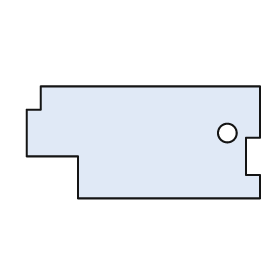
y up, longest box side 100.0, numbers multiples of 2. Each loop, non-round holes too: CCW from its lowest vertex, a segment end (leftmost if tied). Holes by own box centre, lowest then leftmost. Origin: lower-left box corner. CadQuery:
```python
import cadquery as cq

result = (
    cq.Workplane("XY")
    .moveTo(22.0, 0.0)
    .lineTo(100.0, 0.0)
    .lineTo(100.0, 10.0)
    .lineTo(94.0, 10.0)
    .lineTo(94.0, 26.0)
    .lineTo(100.0, 26.0)
    .lineTo(100.0, 48.0)
    .lineTo(6.0, 48.0)
    .lineTo(6.0, 38.0)
    .lineTo(0.0, 38.0)
    .lineTo(0.0, 18.0)
    .lineTo(22.0, 18.0)
    .close()
    .moveTo(86.0, 28.0)
    .circle(4.0)
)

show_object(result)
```